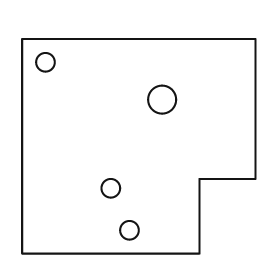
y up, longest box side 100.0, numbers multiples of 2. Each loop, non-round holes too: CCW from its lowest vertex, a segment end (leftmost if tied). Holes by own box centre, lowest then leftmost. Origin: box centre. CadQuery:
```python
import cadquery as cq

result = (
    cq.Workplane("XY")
    .moveTo(-50.0, -46.0)
    .lineTo(26.0, -46.0)
    .lineTo(26.0, -14.0)
    .lineTo(50.0, -14.0)
    .lineTo(50.0, 46.0)
    .lineTo(-50.0, 46.0)
    .close()
    .moveTo(-4.0, -36.0)
    .circle(4.0)
    .moveTo(-12.0, -18.0)
    .circle(4.0)
    .moveTo(10.0, 20.0)
    .circle(6.0)
    .moveTo(-40.0, 36.0)
    .circle(4.0)
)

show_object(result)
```